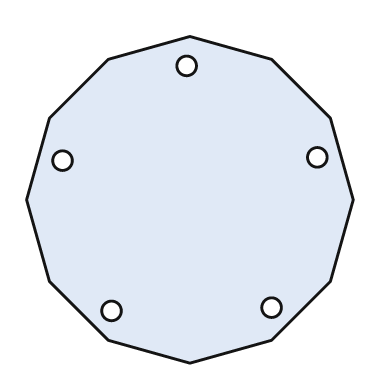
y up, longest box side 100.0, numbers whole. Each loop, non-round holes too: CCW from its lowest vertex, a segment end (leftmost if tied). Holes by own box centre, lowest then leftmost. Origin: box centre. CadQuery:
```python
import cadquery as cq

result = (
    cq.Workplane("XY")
    .moveTo(0.0, -50.0)
    .lineTo(25.0, -43.0)
    .lineTo(43.0, -25.0)
    .lineTo(50.0, 0.0)
    .lineTo(43.0, 25.0)
    .lineTo(25.0, 43.0)
    .lineTo(0.0, 50.0)
    .lineTo(-25.0, 43.0)
    .lineTo(-43.0, 25.0)
    .lineTo(-50.0, 0.0)
    .lineTo(-43.0, -25.0)
    .lineTo(-25.0, -43.0)
    .close()
    .moveTo(-24.0, -34.0)
    .circle(3.0)
    .moveTo(25.0, -33.0)
    .circle(3.0)
    .moveTo(-39.0, 12.0)
    .circle(3.0)
    .moveTo(39.0, 13.0)
    .circle(3.0)
    .moveTo(-1.0, 41.0)
    .circle(3.0)
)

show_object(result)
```